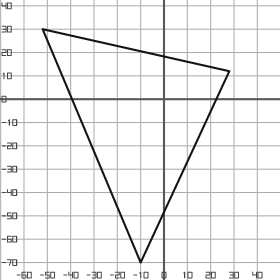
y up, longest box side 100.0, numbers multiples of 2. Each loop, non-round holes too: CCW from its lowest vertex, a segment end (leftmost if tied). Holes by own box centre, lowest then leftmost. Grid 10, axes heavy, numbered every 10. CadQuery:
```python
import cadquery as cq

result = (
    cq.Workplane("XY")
    .moveTo(-10.0, -70.0)
    .lineTo(28.0, 12.0)
    .lineTo(-52.0, 30.0)
    .close()
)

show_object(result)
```